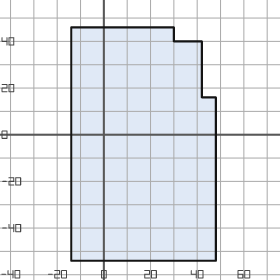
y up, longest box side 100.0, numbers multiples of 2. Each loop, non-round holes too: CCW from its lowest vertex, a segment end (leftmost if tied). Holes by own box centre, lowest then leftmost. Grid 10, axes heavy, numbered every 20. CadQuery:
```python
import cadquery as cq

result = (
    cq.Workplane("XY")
    .moveTo(-14.0, -54.0)
    .lineTo(48.0, -54.0)
    .lineTo(48.0, 16.0)
    .lineTo(42.0, 16.0)
    .lineTo(42.0, 40.0)
    .lineTo(30.0, 40.0)
    .lineTo(30.0, 46.0)
    .lineTo(-14.0, 46.0)
    .close()
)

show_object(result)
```